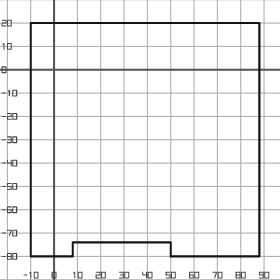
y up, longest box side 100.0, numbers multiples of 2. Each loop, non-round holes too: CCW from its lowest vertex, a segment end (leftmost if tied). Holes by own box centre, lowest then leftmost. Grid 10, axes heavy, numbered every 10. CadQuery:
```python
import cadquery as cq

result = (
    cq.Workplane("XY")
    .moveTo(-10.0, -80.0)
    .lineTo(8.0, -80.0)
    .lineTo(8.0, -74.0)
    .lineTo(50.0, -74.0)
    .lineTo(50.0, -80.0)
    .lineTo(88.0, -80.0)
    .lineTo(88.0, 20.0)
    .lineTo(-10.0, 20.0)
    .close()
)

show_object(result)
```